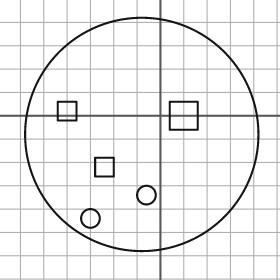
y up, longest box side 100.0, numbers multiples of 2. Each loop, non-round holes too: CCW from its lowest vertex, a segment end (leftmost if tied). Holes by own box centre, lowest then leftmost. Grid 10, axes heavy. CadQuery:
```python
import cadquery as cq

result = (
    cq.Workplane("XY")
    .moveTo(-8.0, -8.0)
    .circle(50.0)
    .moveTo(-30.0, -44.0)
    .circle(4.0)
    .moveTo(-6.0, -34.0)
    .circle(4.0)
    .moveTo(-28.0, -26.0)
    .lineTo(-20.0, -26.0)
    .lineTo(-20.0, -18.0)
    .lineTo(-28.0, -18.0)
    .close()
    .moveTo(4.0, -6.0)
    .lineTo(16.0, -6.0)
    .lineTo(16.0, 6.0)
    .lineTo(4.0, 6.0)
    .close()
    .moveTo(-44.0, -2.0)
    .lineTo(-36.0, -2.0)
    .lineTo(-36.0, 6.0)
    .lineTo(-44.0, 6.0)
    .close()
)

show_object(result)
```